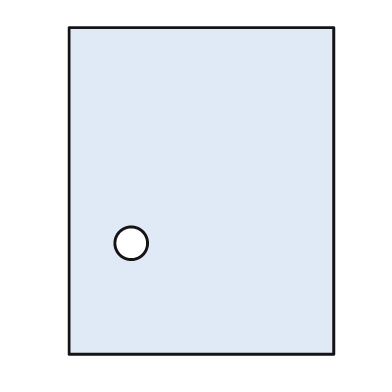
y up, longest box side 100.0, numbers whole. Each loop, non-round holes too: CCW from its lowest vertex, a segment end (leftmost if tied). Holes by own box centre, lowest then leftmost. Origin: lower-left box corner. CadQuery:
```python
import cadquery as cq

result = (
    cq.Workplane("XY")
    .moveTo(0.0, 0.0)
    .lineTo(81.0, 0.0)
    .lineTo(81.0, 100.0)
    .lineTo(0.0, 100.0)
    .close()
    .moveTo(19.0, 34.0)
    .circle(5.0)
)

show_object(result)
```